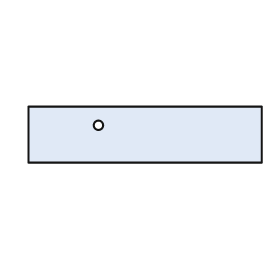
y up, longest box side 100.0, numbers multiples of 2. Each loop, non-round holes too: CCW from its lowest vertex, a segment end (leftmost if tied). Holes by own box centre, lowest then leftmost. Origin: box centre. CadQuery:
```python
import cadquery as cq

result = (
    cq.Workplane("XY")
    .moveTo(-50.0, -12.0)
    .lineTo(50.0, -12.0)
    .lineTo(50.0, 12.0)
    .lineTo(-50.0, 12.0)
    .close()
    .moveTo(-20.0, 4.0)
    .circle(2.0)
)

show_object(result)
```